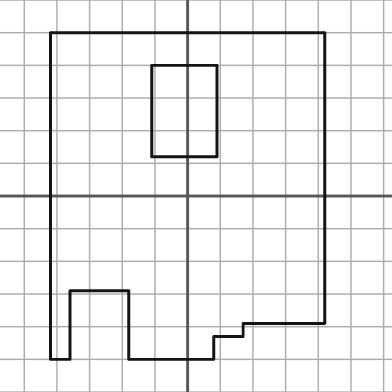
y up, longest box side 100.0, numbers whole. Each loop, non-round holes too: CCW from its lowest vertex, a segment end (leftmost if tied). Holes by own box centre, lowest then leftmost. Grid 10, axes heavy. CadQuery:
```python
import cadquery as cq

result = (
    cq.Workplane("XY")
    .moveTo(-42.0, -50.0)
    .lineTo(-36.0, -50.0)
    .lineTo(-36.0, -29.0)
    .lineTo(-18.0, -29.0)
    .lineTo(-18.0, -50.0)
    .lineTo(8.0, -50.0)
    .lineTo(8.0, -43.0)
    .lineTo(17.0, -43.0)
    .lineTo(17.0, -39.0)
    .lineTo(42.0, -39.0)
    .lineTo(42.0, 50.0)
    .lineTo(-42.0, 50.0)
    .close()
    .moveTo(-11.0, 12.0)
    .lineTo(9.0, 12.0)
    .lineTo(9.0, 40.0)
    .lineTo(-11.0, 40.0)
    .close()
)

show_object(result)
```